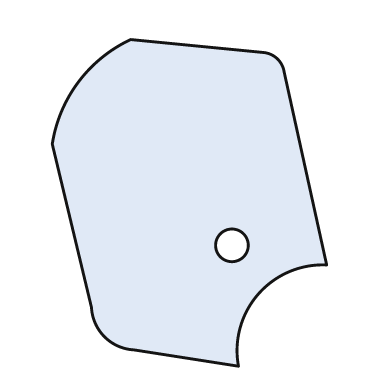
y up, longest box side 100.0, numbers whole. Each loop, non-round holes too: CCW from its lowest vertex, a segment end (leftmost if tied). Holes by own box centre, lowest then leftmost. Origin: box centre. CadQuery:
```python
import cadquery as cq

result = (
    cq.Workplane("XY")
    .moveTo(15.0, -50.0)
    .threePointArc((21.0, -28.0), (42.0, -19.0))
    .lineTo(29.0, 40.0)
    .threePointArc((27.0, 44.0), (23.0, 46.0))
    .lineTo(-18.0, 50.0)
    .threePointArc((-34.0, 37.0), (-42.0, 18.0))
    .lineTo(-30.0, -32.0)
    .threePointArc((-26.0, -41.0), (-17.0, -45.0))
    .close()
    .moveTo(13.0, -13.0)
    .circle(5.0)
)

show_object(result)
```